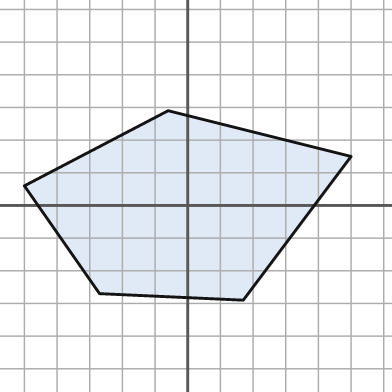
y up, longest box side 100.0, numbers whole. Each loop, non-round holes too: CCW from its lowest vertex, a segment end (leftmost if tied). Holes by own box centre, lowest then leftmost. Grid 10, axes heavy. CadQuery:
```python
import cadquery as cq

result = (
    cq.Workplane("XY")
    .moveTo(17.0, -29.0)
    .lineTo(50.0, 15.0)
    .lineTo(-6.0, 29.0)
    .lineTo(-50.0, 6.0)
    .lineTo(-27.0, -27.0)
    .close()
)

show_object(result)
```